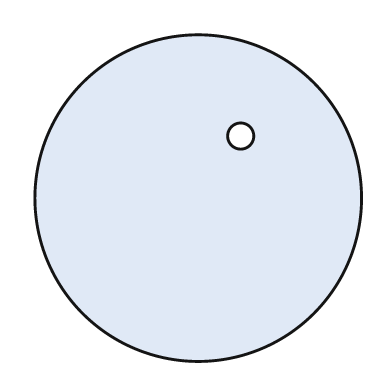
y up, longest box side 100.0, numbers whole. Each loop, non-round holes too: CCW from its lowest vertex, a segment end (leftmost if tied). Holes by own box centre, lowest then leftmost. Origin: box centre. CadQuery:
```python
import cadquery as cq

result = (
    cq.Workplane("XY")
    .moveTo(0.0, 0.0)
    .circle(50.0)
    .moveTo(13.0, 19.0)
    .circle(4.0)
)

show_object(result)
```